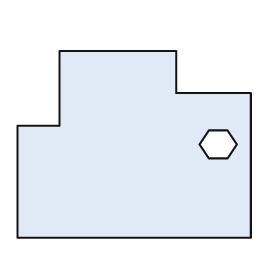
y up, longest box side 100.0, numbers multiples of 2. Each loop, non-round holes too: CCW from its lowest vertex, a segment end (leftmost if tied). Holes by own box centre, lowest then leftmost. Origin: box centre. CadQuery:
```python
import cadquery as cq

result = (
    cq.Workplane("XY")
    .moveTo(-50.0, -40.0)
    .lineTo(50.0, -40.0)
    .lineTo(50.0, 22.0)
    .lineTo(18.0, 22.0)
    .lineTo(18.0, 40.0)
    .lineTo(-32.0, 40.0)
    .lineTo(-32.0, 8.0)
    .lineTo(-50.0, 8.0)
    .close()
    .moveTo(32.0, -6.0)
    .lineTo(40.0, -6.0)
    .lineTo(44.0, 0.0)
    .lineTo(40.0, 6.0)
    .lineTo(32.0, 6.0)
    .lineTo(28.0, 0.0)
    .close()
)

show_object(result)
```